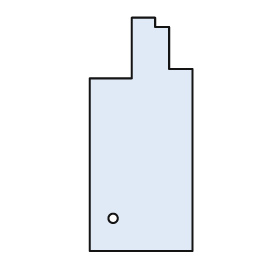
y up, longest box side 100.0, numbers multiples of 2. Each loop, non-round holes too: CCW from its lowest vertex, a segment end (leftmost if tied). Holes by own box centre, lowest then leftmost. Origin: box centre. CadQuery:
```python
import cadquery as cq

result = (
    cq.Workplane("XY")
    .moveTo(-22.0, -50.0)
    .lineTo(22.0, -50.0)
    .lineTo(22.0, 28.0)
    .lineTo(12.0, 28.0)
    .lineTo(12.0, 46.0)
    .lineTo(6.0, 46.0)
    .lineTo(6.0, 50.0)
    .lineTo(-4.0, 50.0)
    .lineTo(-4.0, 24.0)
    .lineTo(-22.0, 24.0)
    .close()
    .moveTo(-12.0, -36.0)
    .circle(2.0)
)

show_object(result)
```